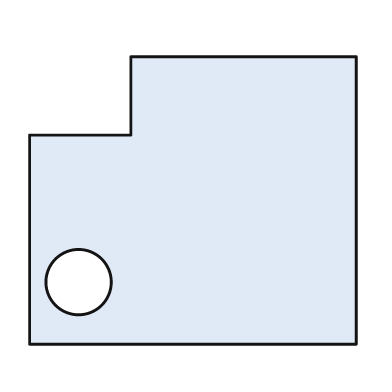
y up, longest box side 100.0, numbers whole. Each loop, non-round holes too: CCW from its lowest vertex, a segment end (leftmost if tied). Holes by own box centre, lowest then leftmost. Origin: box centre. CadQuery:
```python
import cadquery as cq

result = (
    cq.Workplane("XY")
    .moveTo(-50.0, -44.0)
    .lineTo(50.0, -44.0)
    .lineTo(50.0, 44.0)
    .lineTo(-19.0, 44.0)
    .lineTo(-19.0, 20.0)
    .lineTo(-50.0, 20.0)
    .close()
    .moveTo(-35.0, -25.0)
    .circle(10.0)
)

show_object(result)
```